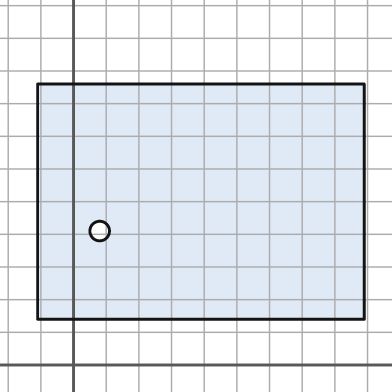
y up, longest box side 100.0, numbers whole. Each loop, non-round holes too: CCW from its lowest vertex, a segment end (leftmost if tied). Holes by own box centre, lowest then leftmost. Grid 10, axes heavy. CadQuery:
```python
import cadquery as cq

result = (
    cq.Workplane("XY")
    .moveTo(-11.0, 14.0)
    .lineTo(89.0, 14.0)
    .lineTo(89.0, 86.0)
    .lineTo(-11.0, 86.0)
    .close()
    .moveTo(8.0, 41.0)
    .circle(3.0)
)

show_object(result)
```